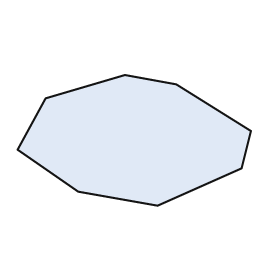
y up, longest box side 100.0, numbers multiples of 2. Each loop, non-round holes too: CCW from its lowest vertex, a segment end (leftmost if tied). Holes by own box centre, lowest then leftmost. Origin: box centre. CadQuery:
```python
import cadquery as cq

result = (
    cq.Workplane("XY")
    .moveTo(10.0, -28.0)
    .lineTo(46.0, -12.0)
    .lineTo(50.0, 4.0)
    .lineTo(18.0, 24.0)
    .lineTo(-4.0, 28.0)
    .lineTo(-38.0, 18.0)
    .lineTo(-50.0, -4.0)
    .lineTo(-24.0, -22.0)
    .close()
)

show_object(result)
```